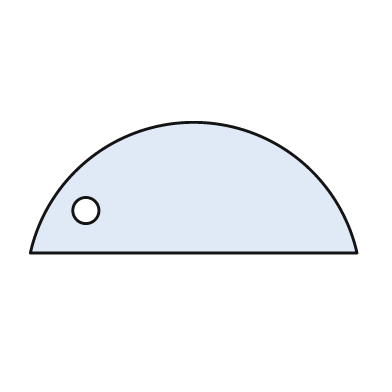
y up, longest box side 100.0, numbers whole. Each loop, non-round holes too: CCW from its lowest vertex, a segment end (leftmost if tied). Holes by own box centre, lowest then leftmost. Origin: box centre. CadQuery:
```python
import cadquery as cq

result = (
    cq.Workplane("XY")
    .moveTo(-50.0, -20.0)
    .lineTo(50.0, -20.0)
    .threePointArc((0.0, 20.0), (-50.0, -20.0))
    .close()
    .moveTo(-33.0, -7.0)
    .circle(4.0)
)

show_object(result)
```